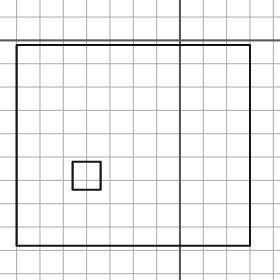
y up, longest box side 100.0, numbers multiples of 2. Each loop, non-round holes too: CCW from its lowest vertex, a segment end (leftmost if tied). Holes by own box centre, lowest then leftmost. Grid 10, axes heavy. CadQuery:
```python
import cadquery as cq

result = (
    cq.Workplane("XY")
    .moveTo(-70.0, -88.0)
    .lineTo(30.0, -88.0)
    .lineTo(30.0, -2.0)
    .lineTo(-70.0, -2.0)
    .close()
    .moveTo(-46.0, -64.0)
    .lineTo(-34.0, -64.0)
    .lineTo(-34.0, -52.0)
    .lineTo(-46.0, -52.0)
    .close()
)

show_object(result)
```